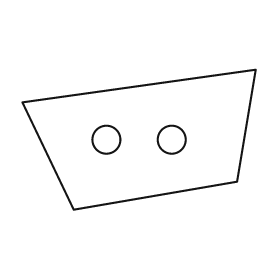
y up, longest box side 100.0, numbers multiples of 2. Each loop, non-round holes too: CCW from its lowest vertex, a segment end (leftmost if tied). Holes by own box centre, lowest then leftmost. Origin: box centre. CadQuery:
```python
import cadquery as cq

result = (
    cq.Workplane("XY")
    .moveTo(-28.0, -30.0)
    .lineTo(42.0, -18.0)
    .lineTo(50.0, 30.0)
    .lineTo(-50.0, 16.0)
    .close()
    .moveTo(-14.0, 0.0)
    .circle(6.0)
    .moveTo(14.0, 0.0)
    .circle(6.0)
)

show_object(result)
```